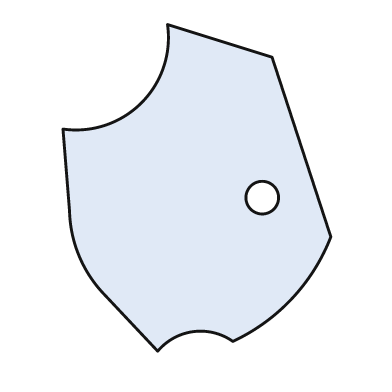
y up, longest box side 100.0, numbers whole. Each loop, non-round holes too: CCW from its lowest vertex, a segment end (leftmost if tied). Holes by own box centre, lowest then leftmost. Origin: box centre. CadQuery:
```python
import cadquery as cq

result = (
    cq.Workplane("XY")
    .moveTo(-12.0, -50.0)
    .threePointArc((-1.0, -44.0), (11.0, -47.0))
    .threePointArc((29.0, -34.0), (41.0, -15.0))
    .lineTo(23.0, 40.0)
    .lineTo(-9.0, 50.0)
    .threePointArc((-17.0, 26.0), (-41.0, 18.0))
    .lineTo(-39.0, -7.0)
    .threePointArc((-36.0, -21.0), (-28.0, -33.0))
    .close()
    .moveTo(20.0, -3.0)
    .circle(5.0)
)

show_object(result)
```